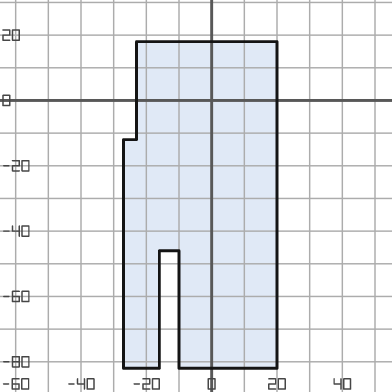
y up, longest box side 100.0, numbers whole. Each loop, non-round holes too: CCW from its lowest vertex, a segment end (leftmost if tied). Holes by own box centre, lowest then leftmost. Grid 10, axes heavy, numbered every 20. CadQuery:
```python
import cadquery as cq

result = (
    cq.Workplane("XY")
    .moveTo(-27.0, -82.0)
    .lineTo(-16.0, -82.0)
    .lineTo(-16.0, -46.0)
    .lineTo(-10.0, -46.0)
    .lineTo(-10.0, -82.0)
    .lineTo(20.0, -82.0)
    .lineTo(20.0, 18.0)
    .lineTo(-23.0, 18.0)
    .lineTo(-23.0, -12.0)
    .lineTo(-27.0, -12.0)
    .close()
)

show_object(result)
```